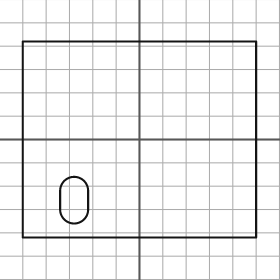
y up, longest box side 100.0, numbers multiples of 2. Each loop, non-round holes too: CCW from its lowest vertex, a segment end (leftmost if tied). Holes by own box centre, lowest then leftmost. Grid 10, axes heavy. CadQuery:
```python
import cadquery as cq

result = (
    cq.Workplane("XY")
    .moveTo(-50.0, -42.0)
    .lineTo(50.0, -42.0)
    .lineTo(50.0, 42.0)
    .lineTo(-50.0, 42.0)
    .close()
    .moveTo(-34.0, -30.0)
    .threePointArc((-28.0, -36.0), (-22.0, -30.0))
    .lineTo(-22.0, -22.0)
    .threePointArc((-28.0, -16.0), (-34.0, -22.0))
    .close()
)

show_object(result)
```